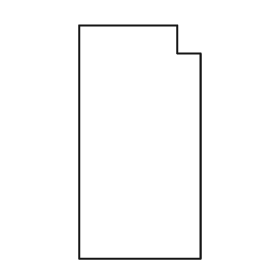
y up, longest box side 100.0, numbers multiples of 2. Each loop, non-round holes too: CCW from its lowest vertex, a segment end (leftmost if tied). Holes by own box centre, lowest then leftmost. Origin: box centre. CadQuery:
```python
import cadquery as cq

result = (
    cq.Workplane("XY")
    .moveTo(-26.0, -50.0)
    .lineTo(26.0, -50.0)
    .lineTo(26.0, 38.0)
    .lineTo(16.0, 38.0)
    .lineTo(16.0, 50.0)
    .lineTo(-26.0, 50.0)
    .close()
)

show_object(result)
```